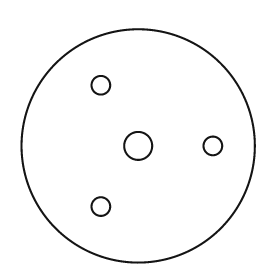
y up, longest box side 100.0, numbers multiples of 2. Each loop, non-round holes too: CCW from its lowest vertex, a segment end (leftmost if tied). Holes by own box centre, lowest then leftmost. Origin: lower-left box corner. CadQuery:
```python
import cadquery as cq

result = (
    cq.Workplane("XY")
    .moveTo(50.0, 50.0)
    .circle(50.0)
    .moveTo(34.0, 24.0)
    .circle(4.0)
    .moveTo(50.0, 50.0)
    .circle(6.0)
    .moveTo(82.0, 50.0)
    .circle(4.0)
    .moveTo(34.0, 76.0)
    .circle(4.0)
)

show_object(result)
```